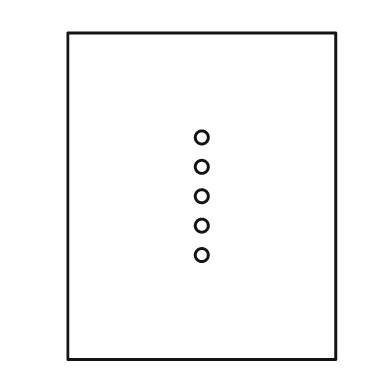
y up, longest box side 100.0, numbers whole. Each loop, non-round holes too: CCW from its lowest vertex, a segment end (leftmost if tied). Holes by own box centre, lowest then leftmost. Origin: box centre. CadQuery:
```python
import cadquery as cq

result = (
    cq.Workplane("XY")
    .moveTo(-41.0, -50.0)
    .lineTo(41.0, -50.0)
    .lineTo(41.0, 50.0)
    .lineTo(-41.0, 50.0)
    .close()
    .moveTo(0.0, -18.0)
    .circle(2.0)
    .moveTo(0.0, -9.0)
    .circle(2.0)
    .moveTo(0.0, 0.0)
    .circle(2.0)
    .moveTo(0.0, 9.0)
    .circle(2.0)
    .moveTo(0.0, 18.0)
    .circle(2.0)
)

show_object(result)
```